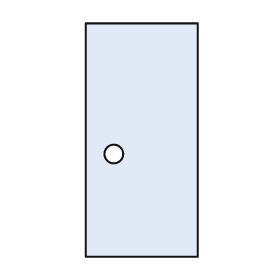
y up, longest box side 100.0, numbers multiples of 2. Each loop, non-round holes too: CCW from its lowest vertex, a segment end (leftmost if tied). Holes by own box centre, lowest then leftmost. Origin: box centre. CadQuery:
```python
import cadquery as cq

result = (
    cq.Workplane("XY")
    .moveTo(-24.0, -50.0)
    .lineTo(24.0, -50.0)
    .lineTo(24.0, 50.0)
    .lineTo(-24.0, 50.0)
    .close()
    .moveTo(-12.0, -6.0)
    .circle(4.0)
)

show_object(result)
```